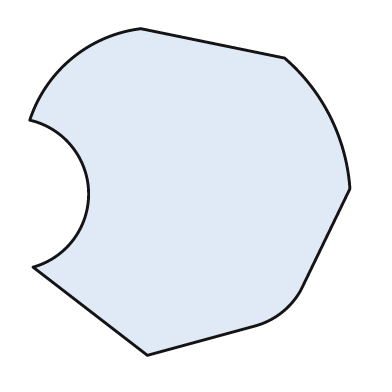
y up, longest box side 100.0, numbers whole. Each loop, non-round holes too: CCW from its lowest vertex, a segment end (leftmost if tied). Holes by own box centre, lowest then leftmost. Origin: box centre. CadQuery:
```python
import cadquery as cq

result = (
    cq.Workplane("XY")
    .moveTo(-13.0, -50.0)
    .lineTo(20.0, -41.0)
    .threePointArc((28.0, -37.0), (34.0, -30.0))
    .lineTo(49.0, 1.0)
    .threePointArc((43.0, 23.0), (29.0, 41.0))
    .lineTo(-15.0, 50.0)
    .threePointArc((-36.0, 41.0), (-49.0, 22.0))
    .threePointArc((-31.0, 0.0), (-48.0, -23.0))
    .close()
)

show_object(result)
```